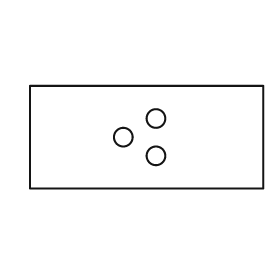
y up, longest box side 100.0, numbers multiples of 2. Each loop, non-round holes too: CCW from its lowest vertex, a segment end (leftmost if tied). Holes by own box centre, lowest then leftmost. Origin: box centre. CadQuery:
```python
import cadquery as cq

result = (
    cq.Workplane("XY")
    .moveTo(-50.0, -22.0)
    .lineTo(50.0, -22.0)
    .lineTo(50.0, 22.0)
    .lineTo(-50.0, 22.0)
    .close()
    .moveTo(4.0, -8.0)
    .circle(4.0)
    .moveTo(-10.0, 0.0)
    .circle(4.0)
    .moveTo(4.0, 8.0)
    .circle(4.0)
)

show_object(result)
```